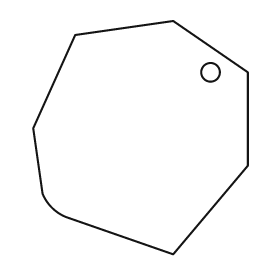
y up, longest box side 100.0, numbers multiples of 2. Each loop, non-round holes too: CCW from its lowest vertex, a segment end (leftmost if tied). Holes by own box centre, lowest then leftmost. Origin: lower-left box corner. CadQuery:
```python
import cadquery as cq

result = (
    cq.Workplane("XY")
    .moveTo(60.0, 0.0)
    .lineTo(92.0, 38.0)
    .lineTo(92.0, 78.0)
    .lineTo(60.0, 100.0)
    .lineTo(18.0, 94.0)
    .lineTo(0.0, 54.0)
    .lineTo(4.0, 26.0)
    .threePointArc((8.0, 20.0), (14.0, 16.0))
    .close()
    .moveTo(76.0, 78.0)
    .circle(4.0)
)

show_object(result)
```